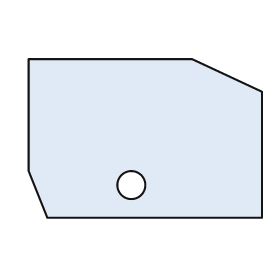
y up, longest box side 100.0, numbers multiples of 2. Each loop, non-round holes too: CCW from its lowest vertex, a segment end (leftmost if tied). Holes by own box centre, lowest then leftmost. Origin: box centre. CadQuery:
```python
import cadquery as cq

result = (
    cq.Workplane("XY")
    .moveTo(-42.0, -34.0)
    .lineTo(50.0, -34.0)
    .lineTo(50.0, 20.0)
    .lineTo(20.0, 34.0)
    .lineTo(-50.0, 34.0)
    .lineTo(-50.0, -14.0)
    .close()
    .moveTo(-6.0, -20.0)
    .circle(6.0)
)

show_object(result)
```